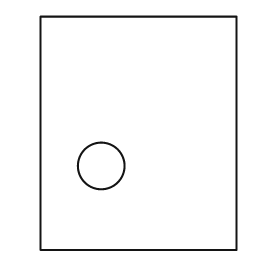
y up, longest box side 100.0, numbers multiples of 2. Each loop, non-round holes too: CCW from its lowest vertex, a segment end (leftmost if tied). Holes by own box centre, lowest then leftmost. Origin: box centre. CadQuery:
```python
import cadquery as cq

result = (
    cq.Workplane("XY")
    .moveTo(-42.0, -50.0)
    .lineTo(42.0, -50.0)
    .lineTo(42.0, 50.0)
    .lineTo(-42.0, 50.0)
    .close()
    .moveTo(-16.0, -14.0)
    .circle(10.0)
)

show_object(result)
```